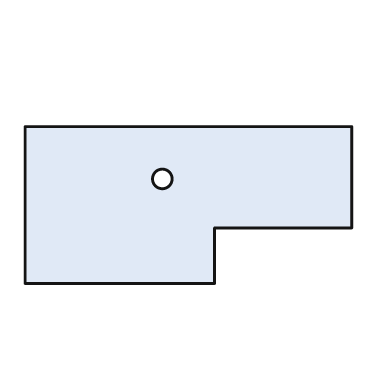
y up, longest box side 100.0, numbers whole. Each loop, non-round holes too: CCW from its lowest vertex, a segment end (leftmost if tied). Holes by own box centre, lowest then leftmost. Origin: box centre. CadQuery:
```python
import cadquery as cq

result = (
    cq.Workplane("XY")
    .moveTo(-50.0, -24.0)
    .lineTo(8.0, -24.0)
    .lineTo(8.0, -7.0)
    .lineTo(50.0, -7.0)
    .lineTo(50.0, 24.0)
    .lineTo(-50.0, 24.0)
    .close()
    .moveTo(-8.0, 8.0)
    .circle(3.0)
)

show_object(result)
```